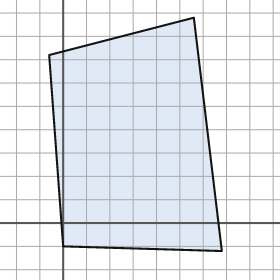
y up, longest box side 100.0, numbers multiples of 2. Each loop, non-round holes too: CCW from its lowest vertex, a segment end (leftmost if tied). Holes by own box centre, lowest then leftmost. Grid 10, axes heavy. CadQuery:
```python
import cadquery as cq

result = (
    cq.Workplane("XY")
    .moveTo(68.0, -12.0)
    .lineTo(56.0, 88.0)
    .lineTo(-6.0, 72.0)
    .lineTo(0.0, -10.0)
    .close()
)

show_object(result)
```